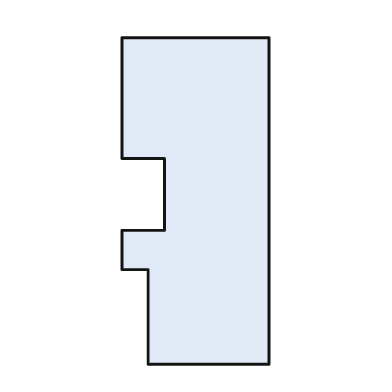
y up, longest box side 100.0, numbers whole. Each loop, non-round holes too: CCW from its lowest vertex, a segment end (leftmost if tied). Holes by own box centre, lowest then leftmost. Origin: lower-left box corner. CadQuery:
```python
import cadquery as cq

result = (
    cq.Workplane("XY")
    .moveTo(8.0, 0.0)
    .lineTo(45.0, 0.0)
    .lineTo(45.0, 100.0)
    .lineTo(0.0, 100.0)
    .lineTo(0.0, 63.0)
    .lineTo(13.0, 63.0)
    .lineTo(13.0, 41.0)
    .lineTo(0.0, 41.0)
    .lineTo(0.0, 29.0)
    .lineTo(8.0, 29.0)
    .close()
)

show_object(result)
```